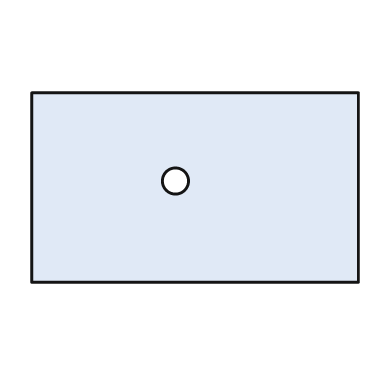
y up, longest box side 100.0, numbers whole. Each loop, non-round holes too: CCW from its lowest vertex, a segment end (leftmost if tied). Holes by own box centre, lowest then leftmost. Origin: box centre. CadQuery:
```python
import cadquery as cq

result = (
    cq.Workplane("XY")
    .moveTo(-50.0, -29.0)
    .lineTo(50.0, -29.0)
    .lineTo(50.0, 29.0)
    .lineTo(-50.0, 29.0)
    .close()
    .moveTo(-6.0, 2.0)
    .circle(4.0)
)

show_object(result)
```